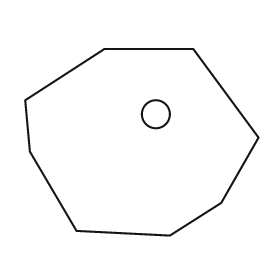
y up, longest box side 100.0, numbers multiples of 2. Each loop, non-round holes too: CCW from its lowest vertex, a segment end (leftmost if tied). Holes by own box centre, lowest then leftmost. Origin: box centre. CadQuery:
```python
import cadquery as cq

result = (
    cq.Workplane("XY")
    .moveTo(12.0, -40.0)
    .lineTo(34.0, -26.0)
    .lineTo(50.0, 2.0)
    .lineTo(22.0, 40.0)
    .lineTo(-16.0, 40.0)
    .lineTo(-50.0, 18.0)
    .lineTo(-48.0, -4.0)
    .lineTo(-28.0, -38.0)
    .close()
    .moveTo(6.0, 12.0)
    .circle(6.0)
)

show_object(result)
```